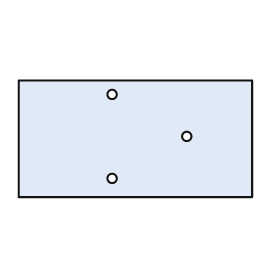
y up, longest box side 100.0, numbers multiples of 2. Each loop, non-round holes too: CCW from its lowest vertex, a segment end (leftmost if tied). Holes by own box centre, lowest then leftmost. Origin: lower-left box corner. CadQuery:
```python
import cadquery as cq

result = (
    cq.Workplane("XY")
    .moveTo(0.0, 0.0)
    .lineTo(100.0, 0.0)
    .lineTo(100.0, 50.0)
    .lineTo(0.0, 50.0)
    .close()
    .moveTo(40.0, 8.0)
    .circle(2.0)
    .moveTo(72.0, 26.0)
    .circle(2.0)
    .moveTo(40.0, 44.0)
    .circle(2.0)
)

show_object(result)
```